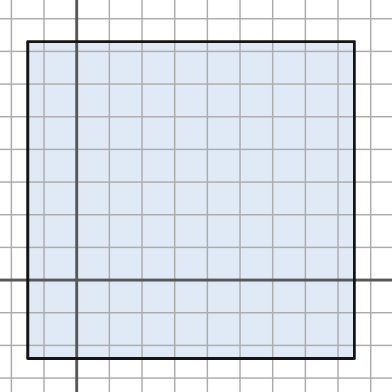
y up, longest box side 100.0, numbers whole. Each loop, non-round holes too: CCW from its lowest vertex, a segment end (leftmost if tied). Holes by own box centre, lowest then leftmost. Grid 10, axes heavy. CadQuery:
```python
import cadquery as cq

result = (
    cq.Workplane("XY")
    .moveTo(-15.0, -24.0)
    .lineTo(85.0, -24.0)
    .lineTo(85.0, 73.0)
    .lineTo(-15.0, 73.0)
    .close()
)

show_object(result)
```